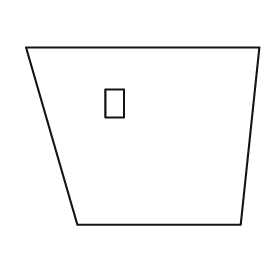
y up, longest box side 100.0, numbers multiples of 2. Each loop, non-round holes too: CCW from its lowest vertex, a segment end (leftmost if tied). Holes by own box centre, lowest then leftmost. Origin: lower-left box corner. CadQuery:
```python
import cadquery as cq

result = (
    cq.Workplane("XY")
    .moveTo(22.0, 0.0)
    .lineTo(92.0, 0.0)
    .lineTo(100.0, 76.0)
    .lineTo(0.0, 76.0)
    .close()
    .moveTo(34.0, 46.0)
    .lineTo(42.0, 46.0)
    .lineTo(42.0, 58.0)
    .lineTo(34.0, 58.0)
    .close()
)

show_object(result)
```